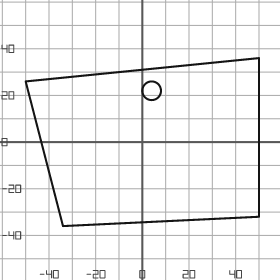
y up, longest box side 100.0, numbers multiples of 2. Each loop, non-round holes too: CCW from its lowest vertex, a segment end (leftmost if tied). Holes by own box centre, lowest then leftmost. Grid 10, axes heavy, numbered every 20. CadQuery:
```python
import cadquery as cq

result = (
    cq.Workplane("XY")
    .moveTo(-34.0, -36.0)
    .lineTo(50.0, -32.0)
    .lineTo(50.0, 36.0)
    .lineTo(-50.0, 26.0)
    .close()
    .moveTo(4.0, 22.0)
    .circle(4.0)
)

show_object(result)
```